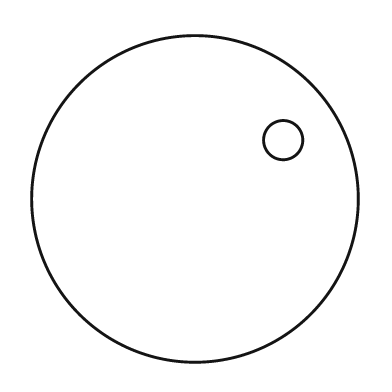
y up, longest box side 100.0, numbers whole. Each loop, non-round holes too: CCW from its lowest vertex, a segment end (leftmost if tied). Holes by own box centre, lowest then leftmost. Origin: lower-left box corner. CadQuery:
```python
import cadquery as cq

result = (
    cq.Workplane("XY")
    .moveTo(50.0, 50.0)
    .circle(50.0)
    .moveTo(77.0, 68.0)
    .circle(6.0)
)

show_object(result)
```